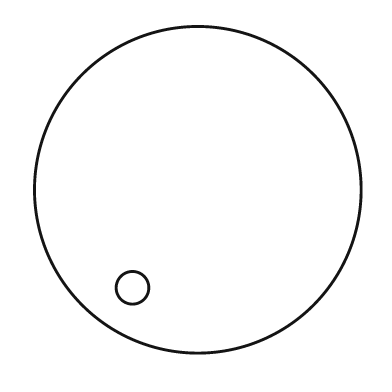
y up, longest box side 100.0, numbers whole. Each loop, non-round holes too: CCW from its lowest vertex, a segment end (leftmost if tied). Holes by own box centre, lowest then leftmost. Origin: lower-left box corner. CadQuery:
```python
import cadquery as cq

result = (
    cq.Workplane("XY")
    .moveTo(50.0, 50.0)
    .circle(50.0)
    .moveTo(30.0, 20.0)
    .circle(5.0)
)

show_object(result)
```